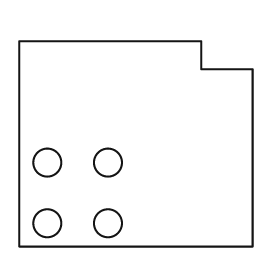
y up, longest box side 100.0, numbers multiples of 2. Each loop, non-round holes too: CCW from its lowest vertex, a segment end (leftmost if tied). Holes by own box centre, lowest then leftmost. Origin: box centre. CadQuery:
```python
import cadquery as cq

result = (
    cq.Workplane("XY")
    .moveTo(-50.0, -44.0)
    .lineTo(50.0, -44.0)
    .lineTo(50.0, 32.0)
    .lineTo(28.0, 32.0)
    .lineTo(28.0, 44.0)
    .lineTo(-50.0, 44.0)
    .close()
    .moveTo(-38.0, -34.0)
    .circle(6.0)
    .moveTo(-12.0, -34.0)
    .circle(6.0)
    .moveTo(-38.0, -8.0)
    .circle(6.0)
    .moveTo(-12.0, -8.0)
    .circle(6.0)
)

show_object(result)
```